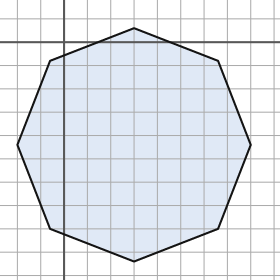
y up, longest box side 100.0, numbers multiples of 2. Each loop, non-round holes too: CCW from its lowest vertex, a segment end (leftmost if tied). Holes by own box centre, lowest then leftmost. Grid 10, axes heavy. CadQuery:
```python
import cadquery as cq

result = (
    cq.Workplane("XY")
    .moveTo(30.0, -94.0)
    .lineTo(66.0, -80.0)
    .lineTo(80.0, -44.0)
    .lineTo(66.0, -8.0)
    .lineTo(30.0, 6.0)
    .lineTo(-6.0, -8.0)
    .lineTo(-20.0, -44.0)
    .lineTo(-6.0, -80.0)
    .close()
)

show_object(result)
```